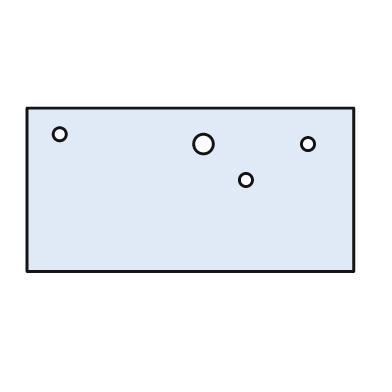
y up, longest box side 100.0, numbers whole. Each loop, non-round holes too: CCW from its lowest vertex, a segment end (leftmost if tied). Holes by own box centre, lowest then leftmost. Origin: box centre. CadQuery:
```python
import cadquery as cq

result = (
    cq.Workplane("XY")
    .moveTo(-50.0, -25.0)
    .lineTo(50.0, -25.0)
    .lineTo(50.0, 25.0)
    .lineTo(-50.0, 25.0)
    .close()
    .moveTo(17.0, 3.0)
    .circle(2.0)
    .moveTo(4.0, 14.0)
    .circle(3.0)
    .moveTo(36.0, 14.0)
    .circle(2.0)
    .moveTo(-40.0, 17.0)
    .circle(2.0)
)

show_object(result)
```